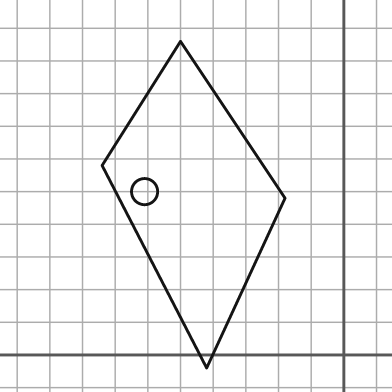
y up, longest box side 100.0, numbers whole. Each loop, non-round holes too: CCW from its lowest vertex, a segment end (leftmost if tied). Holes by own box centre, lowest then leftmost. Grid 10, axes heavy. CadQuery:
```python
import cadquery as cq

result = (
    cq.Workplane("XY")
    .moveTo(-42.0, -4.0)
    .lineTo(-18.0, 48.0)
    .lineTo(-50.0, 96.0)
    .lineTo(-74.0, 58.0)
    .close()
    .moveTo(-61.0, 50.0)
    .circle(4.0)
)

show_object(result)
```